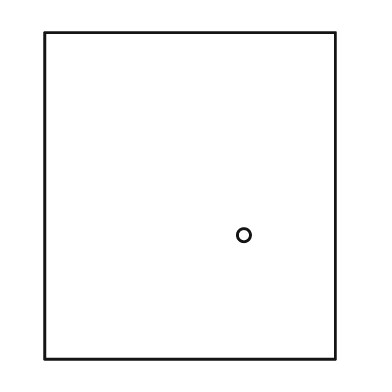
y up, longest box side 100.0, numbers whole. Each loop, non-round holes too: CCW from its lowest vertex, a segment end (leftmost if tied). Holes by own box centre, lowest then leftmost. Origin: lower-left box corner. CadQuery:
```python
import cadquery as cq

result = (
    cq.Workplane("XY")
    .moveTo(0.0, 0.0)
    .lineTo(89.0, 0.0)
    .lineTo(89.0, 100.0)
    .lineTo(0.0, 100.0)
    .close()
    .moveTo(61.0, 38.0)
    .circle(2.0)
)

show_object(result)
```